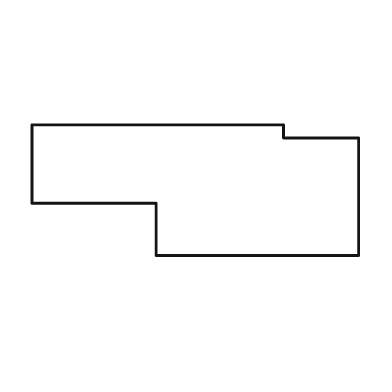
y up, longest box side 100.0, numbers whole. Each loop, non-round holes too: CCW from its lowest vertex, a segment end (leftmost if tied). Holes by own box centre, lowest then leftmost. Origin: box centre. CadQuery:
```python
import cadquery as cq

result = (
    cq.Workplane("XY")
    .moveTo(-12.0, -20.0)
    .lineTo(50.0, -20.0)
    .lineTo(50.0, 16.0)
    .lineTo(27.0, 16.0)
    .lineTo(27.0, 20.0)
    .lineTo(-50.0, 20.0)
    .lineTo(-50.0, -4.0)
    .lineTo(-12.0, -4.0)
    .close()
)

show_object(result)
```